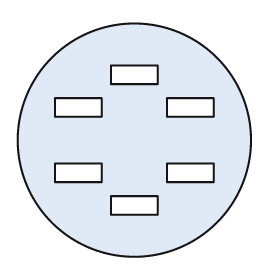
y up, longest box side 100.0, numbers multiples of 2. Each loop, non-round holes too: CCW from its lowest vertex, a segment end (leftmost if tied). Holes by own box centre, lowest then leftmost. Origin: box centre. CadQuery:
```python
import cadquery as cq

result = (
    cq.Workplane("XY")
    .moveTo(0.0, 0.0)
    .circle(50.0)
    .moveTo(-10.0, -32.0)
    .lineTo(10.0, -32.0)
    .lineTo(10.0, -24.0)
    .lineTo(-10.0, -24.0)
    .close()
    .moveTo(-34.0, -18.0)
    .lineTo(-14.0, -18.0)
    .lineTo(-14.0, -10.0)
    .lineTo(-34.0, -10.0)
    .close()
    .moveTo(14.0, -18.0)
    .lineTo(34.0, -18.0)
    .lineTo(34.0, -10.0)
    .lineTo(14.0, -10.0)
    .close()
    .moveTo(-34.0, 10.0)
    .lineTo(-14.0, 10.0)
    .lineTo(-14.0, 18.0)
    .lineTo(-34.0, 18.0)
    .close()
    .moveTo(14.0, 10.0)
    .lineTo(34.0, 10.0)
    .lineTo(34.0, 18.0)
    .lineTo(14.0, 18.0)
    .close()
    .moveTo(-10.0, 24.0)
    .lineTo(10.0, 24.0)
    .lineTo(10.0, 32.0)
    .lineTo(-10.0, 32.0)
    .close()
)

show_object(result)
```